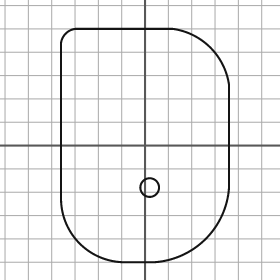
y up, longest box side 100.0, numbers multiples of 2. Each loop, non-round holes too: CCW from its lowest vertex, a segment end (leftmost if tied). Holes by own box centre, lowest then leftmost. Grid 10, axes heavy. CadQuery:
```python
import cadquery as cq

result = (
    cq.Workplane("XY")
    .moveTo(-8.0, -50.0)
    .lineTo(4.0, -50.0)
    .threePointArc((26.0, -40.0), (36.0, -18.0))
    .lineTo(36.0, 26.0)
    .threePointArc((28.0, 42.0), (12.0, 50.0))
    .lineTo(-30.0, 50.0)
    .threePointArc((-34.0, 48.0), (-36.0, 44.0))
    .lineTo(-36.0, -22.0)
    .threePointArc((-28.0, -42.0), (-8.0, -50.0))
    .close()
    .moveTo(2.0, -18.0)
    .circle(4.0)
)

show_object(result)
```